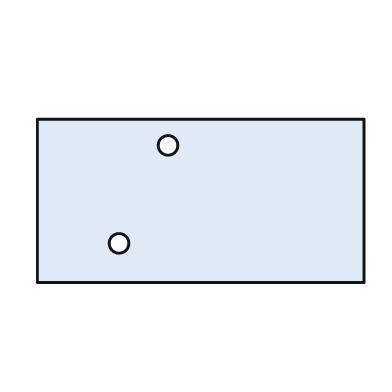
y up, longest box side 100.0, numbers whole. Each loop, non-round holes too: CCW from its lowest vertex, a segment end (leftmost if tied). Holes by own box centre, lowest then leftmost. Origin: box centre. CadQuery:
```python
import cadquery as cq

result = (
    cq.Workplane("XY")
    .moveTo(-50.0, -25.0)
    .lineTo(50.0, -25.0)
    .lineTo(50.0, 25.0)
    .lineTo(-50.0, 25.0)
    .close()
    .moveTo(-25.0, -13.0)
    .circle(3.0)
    .moveTo(-10.0, 17.0)
    .circle(3.0)
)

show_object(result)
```